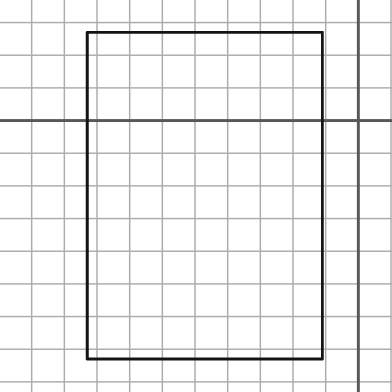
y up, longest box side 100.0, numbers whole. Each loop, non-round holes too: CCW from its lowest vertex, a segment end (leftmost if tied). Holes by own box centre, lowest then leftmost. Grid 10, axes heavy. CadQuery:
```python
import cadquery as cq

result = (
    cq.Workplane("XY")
    .moveTo(-83.0, -73.0)
    .lineTo(-11.0, -73.0)
    .lineTo(-11.0, 27.0)
    .lineTo(-83.0, 27.0)
    .close()
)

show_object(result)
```